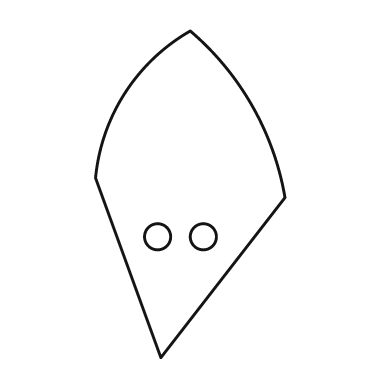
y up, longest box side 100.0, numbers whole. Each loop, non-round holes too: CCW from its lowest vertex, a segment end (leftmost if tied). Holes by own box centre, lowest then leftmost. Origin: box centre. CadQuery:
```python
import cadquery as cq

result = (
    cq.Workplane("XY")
    .moveTo(-9.0, -50.0)
    .lineTo(29.0, -1.0)
    .threePointArc((19.0, 27.0), (0.0, 50.0))
    .threePointArc((-20.0, 31.0), (-29.0, 5.0))
    .close()
    .moveTo(-10.0, -13.0)
    .circle(4.0)
    .moveTo(4.0, -13.0)
    .circle(4.0)
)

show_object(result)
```